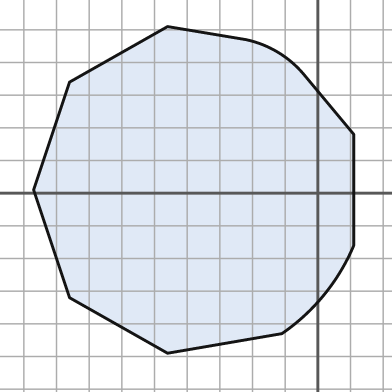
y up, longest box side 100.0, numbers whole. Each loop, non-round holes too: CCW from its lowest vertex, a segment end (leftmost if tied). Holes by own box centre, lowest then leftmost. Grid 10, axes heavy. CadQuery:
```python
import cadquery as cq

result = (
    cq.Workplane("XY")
    .moveTo(-46.0, -49.0)
    .lineTo(-11.0, -43.0)
    .threePointArc((2.0, -31.0), (11.0, -16.0))
    .lineTo(11.0, 18.0)
    .lineTo(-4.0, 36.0)
    .threePointArc((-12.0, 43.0), (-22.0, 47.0))
    .lineTo(-46.0, 51.0)
    .lineTo(-76.0, 34.0)
    .lineTo(-87.0, 1.0)
    .lineTo(-76.0, -32.0)
    .close()
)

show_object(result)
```